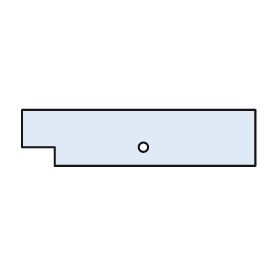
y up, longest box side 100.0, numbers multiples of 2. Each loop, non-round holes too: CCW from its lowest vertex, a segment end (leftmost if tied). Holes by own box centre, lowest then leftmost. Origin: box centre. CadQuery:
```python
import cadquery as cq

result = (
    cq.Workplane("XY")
    .moveTo(-36.0, -12.0)
    .lineTo(50.0, -12.0)
    .lineTo(50.0, 12.0)
    .lineTo(-50.0, 12.0)
    .lineTo(-50.0, -4.0)
    .lineTo(-36.0, -4.0)
    .close()
    .moveTo(2.0, -4.0)
    .circle(2.0)
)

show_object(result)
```